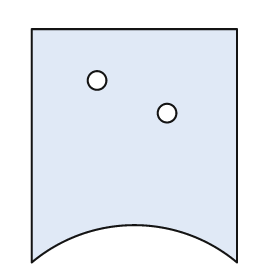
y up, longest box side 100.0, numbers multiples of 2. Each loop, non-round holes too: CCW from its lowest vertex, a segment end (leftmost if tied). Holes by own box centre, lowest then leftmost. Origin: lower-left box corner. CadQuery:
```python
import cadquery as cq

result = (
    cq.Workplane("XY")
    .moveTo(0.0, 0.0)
    .threePointArc((44.0, 16.0), (88.0, 0.0))
    .lineTo(88.0, 100.0)
    .lineTo(0.0, 100.0)
    .close()
    .moveTo(58.0, 64.0)
    .circle(4.0)
    .moveTo(28.0, 78.0)
    .circle(4.0)
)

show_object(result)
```